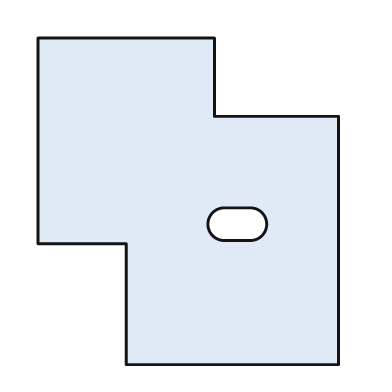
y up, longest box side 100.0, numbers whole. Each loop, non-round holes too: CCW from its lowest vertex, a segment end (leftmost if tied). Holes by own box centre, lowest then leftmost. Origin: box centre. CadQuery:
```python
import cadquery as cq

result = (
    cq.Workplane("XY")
    .moveTo(-19.0, -50.0)
    .lineTo(46.0, -50.0)
    .lineTo(46.0, 26.0)
    .lineTo(8.0, 26.0)
    .lineTo(8.0, 50.0)
    .lineTo(-46.0, 50.0)
    .lineTo(-46.0, -13.0)
    .lineTo(-19.0, -13.0)
    .close()
    .moveTo(11.0, -12.0)
    .lineTo(19.0, -12.0)
    .threePointArc((24.0, -7.0), (19.0, -2.0))
    .lineTo(11.0, -2.0)
    .threePointArc((6.0, -7.0), (11.0, -12.0))
    .close()
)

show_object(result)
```